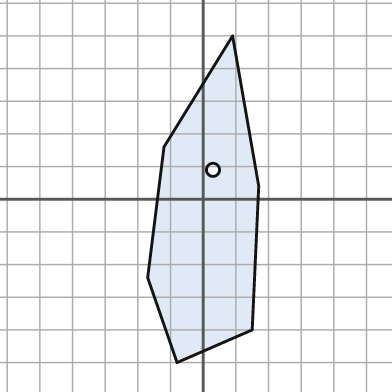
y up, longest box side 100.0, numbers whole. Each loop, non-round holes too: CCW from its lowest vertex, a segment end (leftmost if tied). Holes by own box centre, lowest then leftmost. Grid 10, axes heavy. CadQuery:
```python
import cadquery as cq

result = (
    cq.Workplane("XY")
    .moveTo(-8.0, -50.0)
    .lineTo(15.0, -40.0)
    .lineTo(17.0, 4.0)
    .lineTo(9.0, 50.0)
    .lineTo(-12.0, 16.0)
    .lineTo(-17.0, -24.0)
    .close()
    .moveTo(3.0, 9.0)
    .circle(2.0)
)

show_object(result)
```